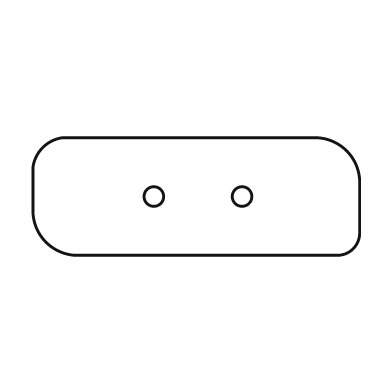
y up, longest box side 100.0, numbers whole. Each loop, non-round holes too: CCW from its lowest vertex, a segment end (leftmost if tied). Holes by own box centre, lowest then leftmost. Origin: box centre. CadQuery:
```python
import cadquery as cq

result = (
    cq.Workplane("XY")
    .moveTo(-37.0, -18.0)
    .lineTo(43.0, -18.0)
    .threePointArc((48.0, -16.0), (50.0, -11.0))
    .lineTo(50.0, 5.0)
    .threePointArc((46.0, 14.0), (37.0, 18.0))
    .lineTo(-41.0, 18.0)
    .threePointArc((-47.0, 15.0), (-50.0, 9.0))
    .lineTo(-50.0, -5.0)
    .threePointArc((-46.0, -14.0), (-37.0, -18.0))
    .close()
    .moveTo(-13.0, 0.0)
    .circle(3.0)
    .moveTo(14.0, 0.0)
    .circle(3.0)
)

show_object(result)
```